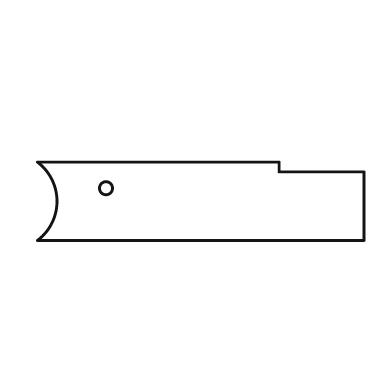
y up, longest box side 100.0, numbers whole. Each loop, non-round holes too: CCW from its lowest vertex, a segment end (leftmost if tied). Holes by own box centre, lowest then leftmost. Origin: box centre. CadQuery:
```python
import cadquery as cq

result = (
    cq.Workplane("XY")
    .moveTo(-50.0, -12.0)
    .lineTo(50.0, -12.0)
    .lineTo(50.0, 9.0)
    .lineTo(24.0, 9.0)
    .lineTo(24.0, 12.0)
    .lineTo(-50.0, 12.0)
    .threePointArc((-44.0, 0.0), (-50.0, -12.0))
    .close()
    .moveTo(-29.0, 4.0)
    .circle(2.0)
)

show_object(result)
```